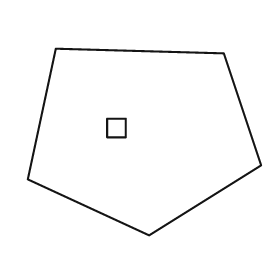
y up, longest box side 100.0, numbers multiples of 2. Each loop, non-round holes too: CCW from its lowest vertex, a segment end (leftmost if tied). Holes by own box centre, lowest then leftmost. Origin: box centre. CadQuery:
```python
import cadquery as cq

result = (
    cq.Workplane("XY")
    .moveTo(2.0, -40.0)
    .lineTo(50.0, -10.0)
    .lineTo(34.0, 38.0)
    .lineTo(-38.0, 40.0)
    .lineTo(-50.0, -16.0)
    .close()
    .moveTo(-16.0, 2.0)
    .lineTo(-8.0, 2.0)
    .lineTo(-8.0, 10.0)
    .lineTo(-16.0, 10.0)
    .close()
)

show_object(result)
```